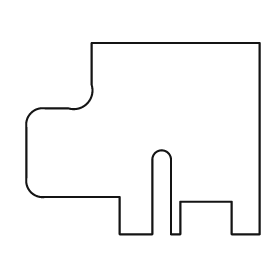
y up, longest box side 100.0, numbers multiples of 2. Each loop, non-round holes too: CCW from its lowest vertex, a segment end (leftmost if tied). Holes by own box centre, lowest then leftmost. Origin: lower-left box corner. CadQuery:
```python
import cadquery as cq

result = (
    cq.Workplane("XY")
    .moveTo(40.0, 0.0)
    .lineTo(54.0, 0.0)
    .lineTo(54.0, 32.0)
    .threePointArc((58.0, 36.0), (62.0, 32.0))
    .lineTo(62.0, 0.0)
    .lineTo(66.0, 0.0)
    .lineTo(66.0, 14.0)
    .lineTo(88.0, 14.0)
    .lineTo(88.0, 0.0)
    .lineTo(100.0, 0.0)
    .lineTo(100.0, 82.0)
    .lineTo(28.0, 82.0)
    .lineTo(28.0, 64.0)
    .threePointArc((26.0, 56.0), (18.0, 54.0))
    .lineTo(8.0, 54.0)
    .threePointArc((2.0, 52.0), (0.0, 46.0))
    .lineTo(0.0, 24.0)
    .threePointArc((2.0, 18.0), (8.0, 16.0))
    .lineTo(40.0, 16.0)
    .close()
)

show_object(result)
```